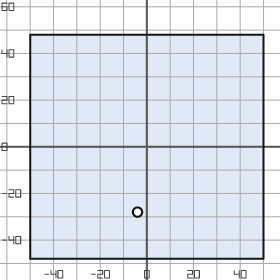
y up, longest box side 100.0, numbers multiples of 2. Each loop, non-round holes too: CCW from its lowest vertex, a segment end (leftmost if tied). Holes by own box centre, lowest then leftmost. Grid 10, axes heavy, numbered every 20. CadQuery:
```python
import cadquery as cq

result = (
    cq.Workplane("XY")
    .moveTo(-50.0, -48.0)
    .lineTo(50.0, -48.0)
    .lineTo(50.0, 48.0)
    .lineTo(-50.0, 48.0)
    .close()
    .moveTo(-4.0, -28.0)
    .circle(2.0)
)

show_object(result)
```